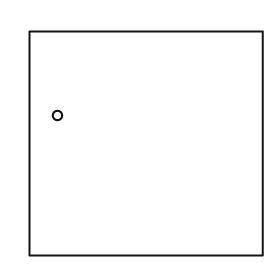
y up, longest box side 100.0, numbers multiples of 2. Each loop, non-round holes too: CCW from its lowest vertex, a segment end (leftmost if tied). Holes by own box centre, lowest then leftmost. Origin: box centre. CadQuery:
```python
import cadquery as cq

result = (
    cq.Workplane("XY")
    .moveTo(-50.0, -48.0)
    .lineTo(50.0, -48.0)
    .lineTo(50.0, 48.0)
    .lineTo(-50.0, 48.0)
    .close()
    .moveTo(-38.0, 12.0)
    .circle(2.0)
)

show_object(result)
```